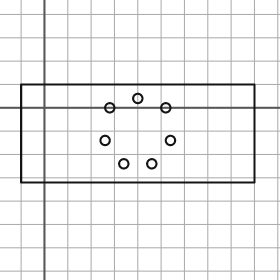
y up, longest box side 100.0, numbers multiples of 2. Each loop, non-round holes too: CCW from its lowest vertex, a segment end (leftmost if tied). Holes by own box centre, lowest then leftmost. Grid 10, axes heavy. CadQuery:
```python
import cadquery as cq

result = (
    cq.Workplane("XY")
    .moveTo(-10.0, -32.0)
    .lineTo(90.0, -32.0)
    .lineTo(90.0, 10.0)
    .lineTo(-10.0, 10.0)
    .close()
    .moveTo(34.0, -24.0)
    .circle(2.0)
    .moveTo(46.0, -24.0)
    .circle(2.0)
    .moveTo(26.0, -14.0)
    .circle(2.0)
    .moveTo(54.0, -14.0)
    .circle(2.0)
    .moveTo(28.0, 0.0)
    .circle(2.0)
    .moveTo(52.0, 0.0)
    .circle(2.0)
    .moveTo(40.0, 4.0)
    .circle(2.0)
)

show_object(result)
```